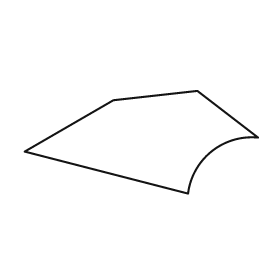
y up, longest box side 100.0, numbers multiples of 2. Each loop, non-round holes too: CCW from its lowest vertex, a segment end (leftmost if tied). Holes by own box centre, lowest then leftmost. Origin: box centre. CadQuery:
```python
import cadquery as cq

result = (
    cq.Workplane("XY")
    .moveTo(20.0, -22.0)
    .threePointArc((30.0, -4.0), (50.0, 2.0))
    .lineTo(24.0, 22.0)
    .lineTo(-12.0, 18.0)
    .lineTo(-50.0, -4.0)
    .close()
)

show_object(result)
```